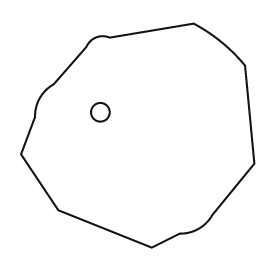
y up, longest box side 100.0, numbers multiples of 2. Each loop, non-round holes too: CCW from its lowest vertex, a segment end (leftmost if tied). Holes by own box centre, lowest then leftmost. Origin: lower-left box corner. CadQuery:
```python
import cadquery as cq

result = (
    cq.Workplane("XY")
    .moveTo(56.0, 0.0)
    .lineTo(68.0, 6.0)
    .threePointArc((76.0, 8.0), (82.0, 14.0))
    .lineTo(100.0, 36.0)
    .lineTo(96.0, 78.0)
    .threePointArc((86.0, 88.0), (74.0, 96.0))
    .lineTo(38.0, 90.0)
    .threePointArc((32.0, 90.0), (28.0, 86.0))
    .lineTo(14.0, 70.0)
    .threePointArc((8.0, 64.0), (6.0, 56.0))
    .lineTo(0.0, 40.0)
    .lineTo(16.0, 16.0)
    .close()
    .moveTo(34.0, 58.0)
    .circle(4.0)
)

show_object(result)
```